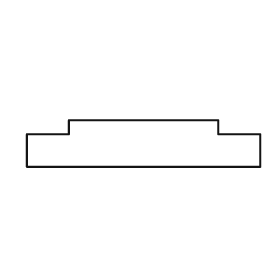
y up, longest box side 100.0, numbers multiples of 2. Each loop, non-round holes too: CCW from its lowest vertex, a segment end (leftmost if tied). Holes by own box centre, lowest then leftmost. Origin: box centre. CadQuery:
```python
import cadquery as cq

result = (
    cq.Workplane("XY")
    .moveTo(-50.0, -10.0)
    .lineTo(50.0, -10.0)
    .lineTo(50.0, 4.0)
    .lineTo(32.0, 4.0)
    .lineTo(32.0, 10.0)
    .lineTo(-32.0, 10.0)
    .lineTo(-32.0, 4.0)
    .lineTo(-50.0, 4.0)
    .close()
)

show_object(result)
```